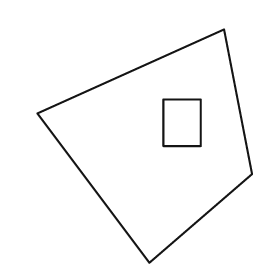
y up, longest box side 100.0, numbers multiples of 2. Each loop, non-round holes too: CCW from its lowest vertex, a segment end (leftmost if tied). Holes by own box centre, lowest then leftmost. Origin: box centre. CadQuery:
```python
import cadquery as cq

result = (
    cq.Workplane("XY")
    .moveTo(2.0, -50.0)
    .lineTo(46.0, -12.0)
    .lineTo(34.0, 50.0)
    .lineTo(-46.0, 14.0)
    .close()
    .moveTo(8.0, 0.0)
    .lineTo(24.0, 0.0)
    .lineTo(24.0, 20.0)
    .lineTo(8.0, 20.0)
    .close()
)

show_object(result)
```